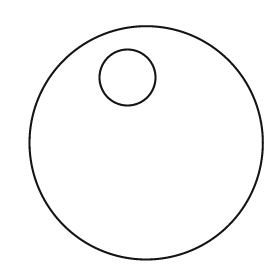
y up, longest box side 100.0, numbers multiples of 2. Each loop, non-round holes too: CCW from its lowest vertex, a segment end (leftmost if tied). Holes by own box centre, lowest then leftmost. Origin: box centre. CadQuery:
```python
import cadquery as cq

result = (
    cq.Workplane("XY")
    .moveTo(0.0, 0.0)
    .circle(50.0)
    .moveTo(-8.0, 28.0)
    .circle(12.0)
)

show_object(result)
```